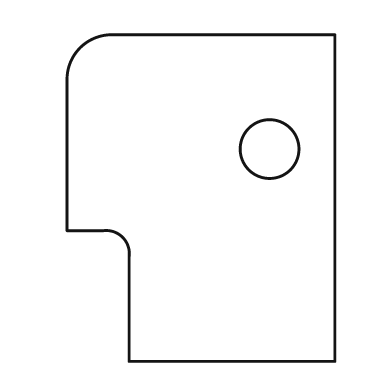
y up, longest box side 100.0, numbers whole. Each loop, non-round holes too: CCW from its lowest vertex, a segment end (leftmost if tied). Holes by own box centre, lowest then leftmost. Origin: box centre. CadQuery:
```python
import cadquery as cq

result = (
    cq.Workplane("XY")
    .moveTo(-22.0, -50.0)
    .lineTo(41.0, -50.0)
    .lineTo(41.0, 50.0)
    .lineTo(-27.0, 50.0)
    .threePointArc((-37.0, 46.0), (-41.0, 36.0))
    .lineTo(-41.0, -10.0)
    .lineTo(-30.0, -10.0)
    .threePointArc((-24.0, -12.0), (-22.0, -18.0))
    .close()
    .moveTo(21.0, 15.0)
    .circle(9.0)
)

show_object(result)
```